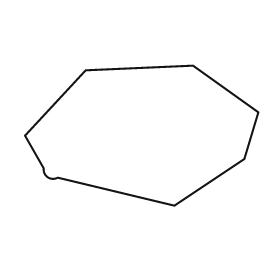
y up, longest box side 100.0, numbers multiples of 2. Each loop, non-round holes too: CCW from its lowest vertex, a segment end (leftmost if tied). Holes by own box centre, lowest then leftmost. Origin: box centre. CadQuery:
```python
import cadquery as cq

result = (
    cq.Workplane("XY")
    .moveTo(14.0, -30.0)
    .lineTo(44.0, -10.0)
    .lineTo(50.0, 10.0)
    .lineTo(22.0, 30.0)
    .lineTo(-24.0, 28.0)
    .lineTo(-50.0, 0.0)
    .lineTo(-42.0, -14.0)
    .threePointArc((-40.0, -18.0), (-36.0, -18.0))
    .close()
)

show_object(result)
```